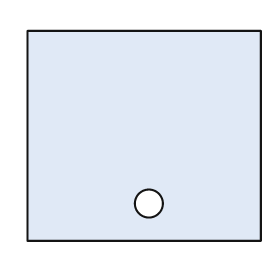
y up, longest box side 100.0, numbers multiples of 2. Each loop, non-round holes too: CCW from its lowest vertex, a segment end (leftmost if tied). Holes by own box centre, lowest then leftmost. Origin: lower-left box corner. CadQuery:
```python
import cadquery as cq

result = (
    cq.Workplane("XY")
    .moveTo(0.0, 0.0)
    .lineTo(100.0, 0.0)
    .lineTo(100.0, 90.0)
    .lineTo(0.0, 90.0)
    .close()
    .moveTo(52.0, 16.0)
    .circle(6.0)
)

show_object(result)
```